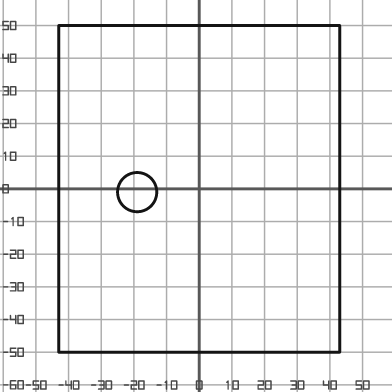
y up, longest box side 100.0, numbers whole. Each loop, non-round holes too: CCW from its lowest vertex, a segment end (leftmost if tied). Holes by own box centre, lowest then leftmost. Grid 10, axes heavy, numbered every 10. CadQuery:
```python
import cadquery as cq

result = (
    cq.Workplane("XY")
    .moveTo(-43.0, -50.0)
    .lineTo(43.0, -50.0)
    .lineTo(43.0, 50.0)
    .lineTo(-43.0, 50.0)
    .close()
    .moveTo(-19.0, -1.0)
    .circle(6.0)
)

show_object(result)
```